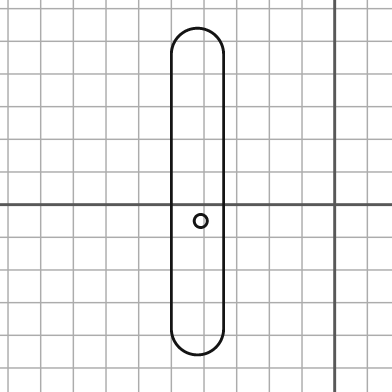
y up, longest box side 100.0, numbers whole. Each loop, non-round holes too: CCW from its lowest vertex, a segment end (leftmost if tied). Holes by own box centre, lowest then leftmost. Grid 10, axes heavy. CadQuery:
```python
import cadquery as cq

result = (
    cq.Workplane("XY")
    .moveTo(-50.0, -38.0)
    .threePointArc((-42.0, -46.0), (-34.0, -38.0))
    .lineTo(-34.0, 46.0)
    .threePointArc((-42.0, 54.0), (-50.0, 46.0))
    .close()
    .moveTo(-41.0, -5.0)
    .circle(2.0)
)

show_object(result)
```